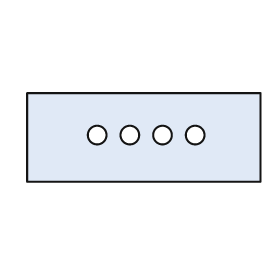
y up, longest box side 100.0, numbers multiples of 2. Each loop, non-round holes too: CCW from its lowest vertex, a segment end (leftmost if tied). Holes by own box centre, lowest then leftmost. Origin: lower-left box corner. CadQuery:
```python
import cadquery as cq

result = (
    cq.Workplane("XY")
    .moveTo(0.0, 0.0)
    .lineTo(100.0, 0.0)
    .lineTo(100.0, 38.0)
    .lineTo(0.0, 38.0)
    .close()
    .moveTo(30.0, 20.0)
    .circle(4.0)
    .moveTo(44.0, 20.0)
    .circle(4.0)
    .moveTo(58.0, 20.0)
    .circle(4.0)
    .moveTo(72.0, 20.0)
    .circle(4.0)
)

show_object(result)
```